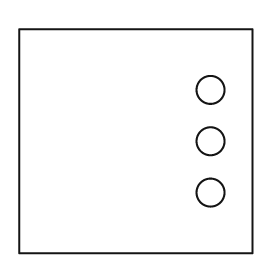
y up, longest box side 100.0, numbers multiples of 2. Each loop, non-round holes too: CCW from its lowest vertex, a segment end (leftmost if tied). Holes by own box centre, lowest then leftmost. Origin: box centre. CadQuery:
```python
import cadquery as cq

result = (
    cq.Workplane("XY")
    .moveTo(-50.0, -48.0)
    .lineTo(50.0, -48.0)
    .lineTo(50.0, 48.0)
    .lineTo(-50.0, 48.0)
    .close()
    .moveTo(32.0, -22.0)
    .circle(6.0)
    .moveTo(32.0, 0.0)
    .circle(6.0)
    .moveTo(32.0, 22.0)
    .circle(6.0)
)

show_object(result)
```